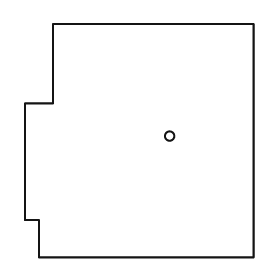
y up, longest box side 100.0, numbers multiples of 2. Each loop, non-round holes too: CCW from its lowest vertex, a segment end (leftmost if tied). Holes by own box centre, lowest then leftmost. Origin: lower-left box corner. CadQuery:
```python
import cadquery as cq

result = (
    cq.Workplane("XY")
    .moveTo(6.0, 0.0)
    .lineTo(98.0, 0.0)
    .lineTo(98.0, 100.0)
    .lineTo(12.0, 100.0)
    .lineTo(12.0, 66.0)
    .lineTo(0.0, 66.0)
    .lineTo(0.0, 16.0)
    .lineTo(6.0, 16.0)
    .close()
    .moveTo(62.0, 52.0)
    .circle(2.0)
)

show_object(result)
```